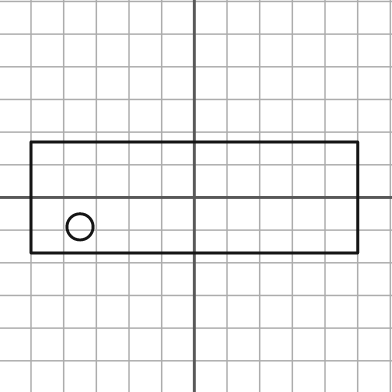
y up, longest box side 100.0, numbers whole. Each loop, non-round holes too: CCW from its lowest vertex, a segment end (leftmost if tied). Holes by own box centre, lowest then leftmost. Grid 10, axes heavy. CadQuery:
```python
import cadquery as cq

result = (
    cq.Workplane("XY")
    .moveTo(-50.0, -17.0)
    .lineTo(50.0, -17.0)
    .lineTo(50.0, 17.0)
    .lineTo(-50.0, 17.0)
    .close()
    .moveTo(-35.0, -9.0)
    .circle(4.0)
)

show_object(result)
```